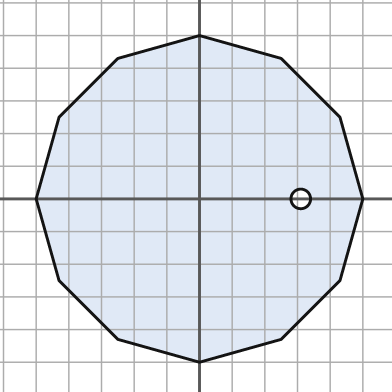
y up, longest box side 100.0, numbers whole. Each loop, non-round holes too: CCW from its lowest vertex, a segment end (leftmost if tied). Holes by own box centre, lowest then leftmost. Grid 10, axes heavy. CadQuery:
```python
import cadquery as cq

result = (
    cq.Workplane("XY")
    .moveTo(0.0, -50.0)
    .lineTo(25.0, -43.0)
    .lineTo(43.0, -25.0)
    .lineTo(50.0, 0.0)
    .lineTo(43.0, 25.0)
    .lineTo(25.0, 43.0)
    .lineTo(0.0, 50.0)
    .lineTo(-25.0, 43.0)
    .lineTo(-43.0, 25.0)
    .lineTo(-50.0, 0.0)
    .lineTo(-43.0, -25.0)
    .lineTo(-25.0, -43.0)
    .close()
    .moveTo(31.0, 0.0)
    .circle(3.0)
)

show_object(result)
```